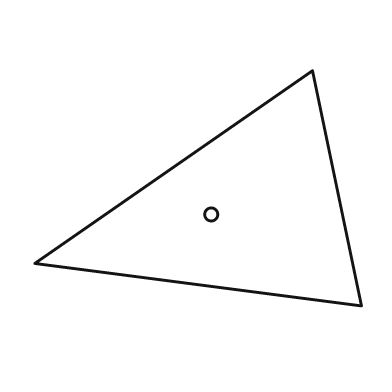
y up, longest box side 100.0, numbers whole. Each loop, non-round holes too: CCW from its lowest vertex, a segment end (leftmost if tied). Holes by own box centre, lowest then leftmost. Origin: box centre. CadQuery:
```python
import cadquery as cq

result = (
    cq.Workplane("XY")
    .moveTo(50.0, -36.0)
    .lineTo(35.0, 36.0)
    .lineTo(-50.0, -23.0)
    .close()
    .moveTo(4.0, -8.0)
    .circle(2.0)
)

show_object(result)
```